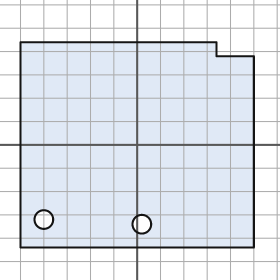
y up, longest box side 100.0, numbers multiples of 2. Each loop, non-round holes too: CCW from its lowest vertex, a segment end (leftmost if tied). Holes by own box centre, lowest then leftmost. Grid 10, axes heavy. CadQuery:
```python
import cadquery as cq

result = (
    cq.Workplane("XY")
    .moveTo(-50.0, -44.0)
    .lineTo(50.0, -44.0)
    .lineTo(50.0, 38.0)
    .lineTo(34.0, 38.0)
    .lineTo(34.0, 44.0)
    .lineTo(-50.0, 44.0)
    .close()
    .moveTo(2.0, -34.0)
    .circle(4.0)
    .moveTo(-40.0, -32.0)
    .circle(4.0)
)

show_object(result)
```